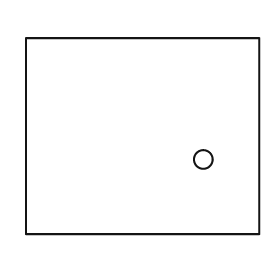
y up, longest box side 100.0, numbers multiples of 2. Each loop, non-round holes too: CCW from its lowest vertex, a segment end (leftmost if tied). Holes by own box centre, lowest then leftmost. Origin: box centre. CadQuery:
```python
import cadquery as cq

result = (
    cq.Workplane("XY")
    .moveTo(-50.0, -42.0)
    .lineTo(50.0, -42.0)
    .lineTo(50.0, 42.0)
    .lineTo(-50.0, 42.0)
    .close()
    .moveTo(26.0, -10.0)
    .circle(4.0)
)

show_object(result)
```